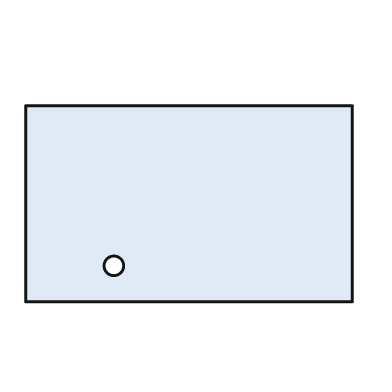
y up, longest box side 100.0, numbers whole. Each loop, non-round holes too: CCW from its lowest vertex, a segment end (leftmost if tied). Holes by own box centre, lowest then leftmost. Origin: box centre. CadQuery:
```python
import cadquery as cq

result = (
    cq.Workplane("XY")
    .moveTo(-50.0, -30.0)
    .lineTo(50.0, -30.0)
    .lineTo(50.0, 30.0)
    .lineTo(-50.0, 30.0)
    .close()
    .moveTo(-23.0, -19.0)
    .circle(3.0)
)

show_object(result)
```